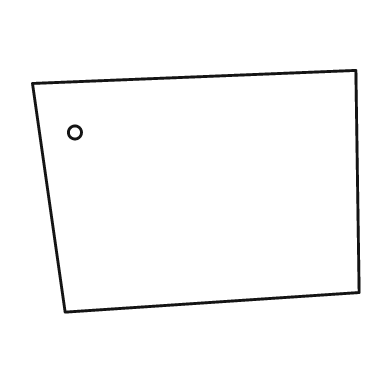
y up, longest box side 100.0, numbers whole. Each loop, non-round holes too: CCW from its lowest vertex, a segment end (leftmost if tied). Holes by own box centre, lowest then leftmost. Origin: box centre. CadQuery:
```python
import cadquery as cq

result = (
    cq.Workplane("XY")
    .moveTo(-40.0, -37.0)
    .lineTo(50.0, -31.0)
    .lineTo(49.0, 37.0)
    .lineTo(-50.0, 33.0)
    .close()
    .moveTo(-37.0, 18.0)
    .circle(2.0)
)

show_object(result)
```